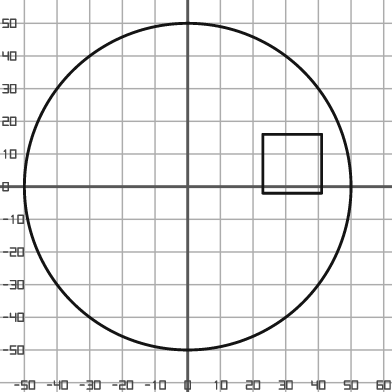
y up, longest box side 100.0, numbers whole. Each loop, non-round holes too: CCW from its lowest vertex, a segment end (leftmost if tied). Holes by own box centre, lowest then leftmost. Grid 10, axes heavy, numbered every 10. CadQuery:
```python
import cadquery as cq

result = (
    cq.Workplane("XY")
    .moveTo(0.0, 0.0)
    .circle(50.0)
    .moveTo(23.0, -2.0)
    .lineTo(41.0, -2.0)
    .lineTo(41.0, 16.0)
    .lineTo(23.0, 16.0)
    .close()
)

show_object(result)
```